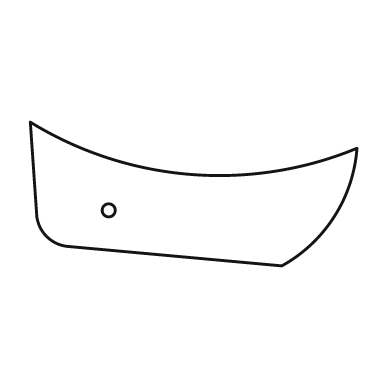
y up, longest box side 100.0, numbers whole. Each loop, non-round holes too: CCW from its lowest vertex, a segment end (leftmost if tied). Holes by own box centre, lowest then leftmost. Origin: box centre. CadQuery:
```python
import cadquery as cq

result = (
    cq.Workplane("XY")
    .moveTo(27.0, -22.0)
    .threePointArc((43.0, -7.0), (50.0, 14.0))
    .threePointArc((-1.0, 6.0), (-50.0, 22.0))
    .lineTo(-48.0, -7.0)
    .threePointArc((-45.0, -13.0), (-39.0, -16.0))
    .close()
    .moveTo(-26.0, -5.0)
    .circle(2.0)
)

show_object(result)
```